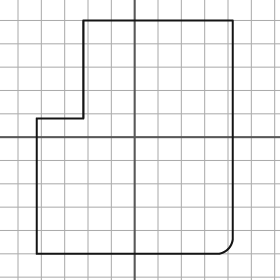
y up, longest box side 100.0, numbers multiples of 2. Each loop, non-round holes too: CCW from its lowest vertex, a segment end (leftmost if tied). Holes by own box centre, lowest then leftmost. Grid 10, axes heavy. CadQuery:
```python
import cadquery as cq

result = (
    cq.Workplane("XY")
    .moveTo(-42.0, -50.0)
    .lineTo(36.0, -50.0)
    .threePointArc((40.0, -48.0), (42.0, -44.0))
    .lineTo(42.0, 50.0)
    .lineTo(-22.0, 50.0)
    .lineTo(-22.0, 8.0)
    .lineTo(-42.0, 8.0)
    .close()
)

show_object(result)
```